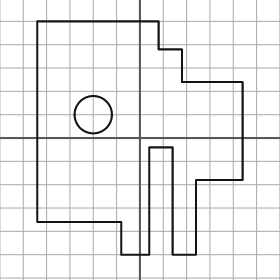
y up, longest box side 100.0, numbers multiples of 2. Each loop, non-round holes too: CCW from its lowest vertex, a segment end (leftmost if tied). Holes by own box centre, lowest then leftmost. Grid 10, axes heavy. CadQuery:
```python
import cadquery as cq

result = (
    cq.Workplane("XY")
    .moveTo(-8.0, -50.0)
    .lineTo(4.0, -50.0)
    .lineTo(4.0, -4.0)
    .lineTo(14.0, -4.0)
    .lineTo(14.0, -50.0)
    .lineTo(24.0, -50.0)
    .lineTo(24.0, -18.0)
    .lineTo(44.0, -18.0)
    .lineTo(44.0, 24.0)
    .lineTo(18.0, 24.0)
    .lineTo(18.0, 38.0)
    .lineTo(8.0, 38.0)
    .lineTo(8.0, 50.0)
    .lineTo(-44.0, 50.0)
    .lineTo(-44.0, -36.0)
    .lineTo(-8.0, -36.0)
    .close()
    .moveTo(-20.0, 10.0)
    .circle(8.0)
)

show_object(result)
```